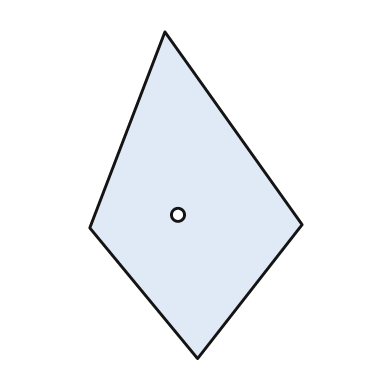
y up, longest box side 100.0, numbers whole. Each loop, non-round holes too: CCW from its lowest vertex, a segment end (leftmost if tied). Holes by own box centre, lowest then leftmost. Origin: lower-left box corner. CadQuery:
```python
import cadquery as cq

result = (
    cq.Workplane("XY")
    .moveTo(33.0, 0.0)
    .lineTo(65.0, 41.0)
    .lineTo(23.0, 100.0)
    .lineTo(0.0, 40.0)
    .close()
    .moveTo(27.0, 44.0)
    .circle(2.0)
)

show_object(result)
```